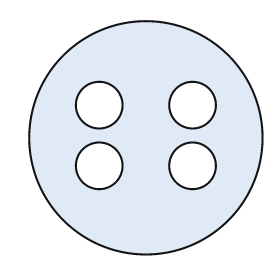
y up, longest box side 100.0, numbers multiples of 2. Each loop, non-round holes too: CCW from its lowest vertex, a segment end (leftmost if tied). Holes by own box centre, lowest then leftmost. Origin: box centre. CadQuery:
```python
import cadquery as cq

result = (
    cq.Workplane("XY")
    .moveTo(0.0, 0.0)
    .circle(50.0)
    .moveTo(-20.0, -12.0)
    .circle(10.0)
    .moveTo(20.0, -12.0)
    .circle(10.0)
    .moveTo(-20.0, 14.0)
    .circle(10.0)
    .moveTo(20.0, 14.0)
    .circle(10.0)
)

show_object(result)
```